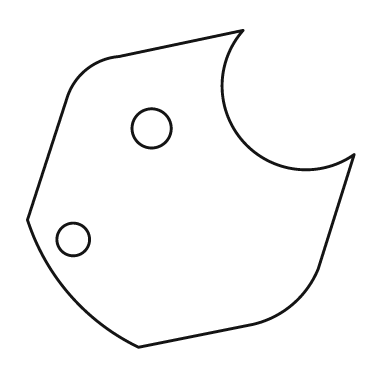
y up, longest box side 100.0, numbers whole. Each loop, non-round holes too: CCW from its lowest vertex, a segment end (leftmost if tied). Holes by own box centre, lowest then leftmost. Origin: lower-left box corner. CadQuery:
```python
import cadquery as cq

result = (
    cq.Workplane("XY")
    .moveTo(34.0, 0.0)
    .lineTo(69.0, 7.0)
    .threePointArc((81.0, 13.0), (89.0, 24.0))
    .lineTo(100.0, 59.0)
    .threePointArc((66.0, 63.0), (66.0, 97.0))
    .lineTo(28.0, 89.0)
    .threePointArc((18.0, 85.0), (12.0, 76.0))
    .lineTo(0.0, 39.0)
    .threePointArc((13.0, 16.0), (34.0, 0.0))
    .close()
    .moveTo(14.0, 33.0)
    .circle(5.0)
    .moveTo(38.0, 67.0)
    .circle(6.0)
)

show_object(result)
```